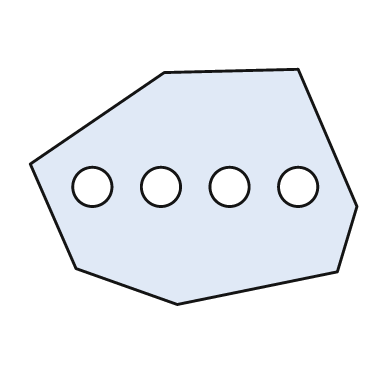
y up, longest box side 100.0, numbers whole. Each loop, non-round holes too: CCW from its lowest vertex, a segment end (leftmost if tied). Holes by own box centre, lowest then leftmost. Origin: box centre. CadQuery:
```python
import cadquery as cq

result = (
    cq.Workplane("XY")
    .moveTo(-5.0, -36.0)
    .lineTo(44.0, -26.0)
    .lineTo(50.0, -6.0)
    .lineTo(32.0, 36.0)
    .lineTo(-9.0, 35.0)
    .lineTo(-50.0, 7.0)
    .lineTo(-36.0, -25.0)
    .close()
    .moveTo(-31.0, 0.0)
    .circle(6.0)
    .moveTo(-10.0, 0.0)
    .circle(6.0)
    .moveTo(11.0, 0.0)
    .circle(6.0)
    .moveTo(32.0, 0.0)
    .circle(6.0)
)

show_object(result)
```